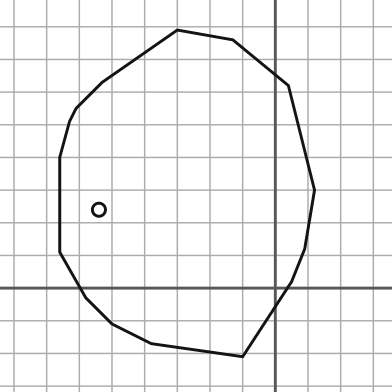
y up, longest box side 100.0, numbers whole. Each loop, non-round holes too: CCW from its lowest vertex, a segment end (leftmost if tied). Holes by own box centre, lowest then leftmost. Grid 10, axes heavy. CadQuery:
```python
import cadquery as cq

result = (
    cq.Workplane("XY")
    .moveTo(-10.0, -21.0)
    .lineTo(5.0, 2.0)
    .lineTo(9.0, 12.0)
    .lineTo(12.0, 30.0)
    .lineTo(4.0, 62.0)
    .lineTo(-13.0, 76.0)
    .lineTo(-30.0, 79.0)
    .lineTo(-53.0, 63.0)
    .lineTo(-61.0, 55.0)
    .lineTo(-63.0, 51.0)
    .lineTo(-66.0, 40.0)
    .lineTo(-66.0, 11.0)
    .lineTo(-58.0, -3.0)
    .lineTo(-50.0, -11.0)
    .lineTo(-38.0, -17.0)
    .close()
    .moveTo(-54.0, 24.0)
    .circle(2.0)
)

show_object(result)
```